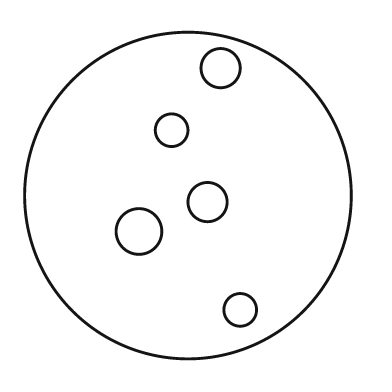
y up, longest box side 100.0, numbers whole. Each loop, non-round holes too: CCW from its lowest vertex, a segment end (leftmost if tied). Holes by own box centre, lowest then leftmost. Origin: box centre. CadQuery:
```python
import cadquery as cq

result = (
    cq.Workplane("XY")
    .moveTo(0.0, 0.0)
    .circle(50.0)
    .moveTo(16.0, -35.0)
    .circle(5.0)
    .moveTo(-15.0, -11.0)
    .circle(7.0)
    .moveTo(6.0, -2.0)
    .circle(6.0)
    .moveTo(-5.0, 20.0)
    .circle(5.0)
    .moveTo(10.0, 39.0)
    .circle(6.0)
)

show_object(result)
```